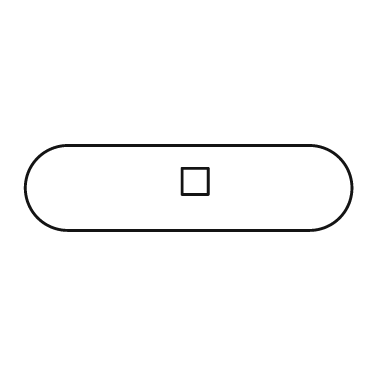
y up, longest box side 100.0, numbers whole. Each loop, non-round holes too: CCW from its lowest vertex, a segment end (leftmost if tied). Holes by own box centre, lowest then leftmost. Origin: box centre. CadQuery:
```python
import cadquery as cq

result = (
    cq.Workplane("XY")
    .moveTo(-37.0, -13.0)
    .lineTo(37.0, -13.0)
    .threePointArc((50.0, 0.0), (37.0, 13.0))
    .lineTo(-37.0, 13.0)
    .threePointArc((-50.0, 0.0), (-37.0, -13.0))
    .close()
    .moveTo(-2.0, -2.0)
    .lineTo(6.0, -2.0)
    .lineTo(6.0, 6.0)
    .lineTo(-2.0, 6.0)
    .close()
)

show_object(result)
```